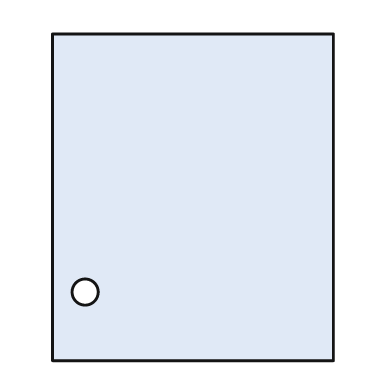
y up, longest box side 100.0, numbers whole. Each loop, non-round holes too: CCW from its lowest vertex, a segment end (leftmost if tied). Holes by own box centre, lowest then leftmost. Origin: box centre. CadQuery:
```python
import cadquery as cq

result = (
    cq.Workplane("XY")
    .moveTo(-43.0, -50.0)
    .lineTo(43.0, -50.0)
    .lineTo(43.0, 50.0)
    .lineTo(-43.0, 50.0)
    .close()
    .moveTo(-33.0, -29.0)
    .circle(4.0)
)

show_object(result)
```